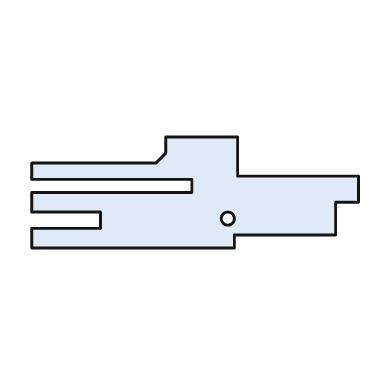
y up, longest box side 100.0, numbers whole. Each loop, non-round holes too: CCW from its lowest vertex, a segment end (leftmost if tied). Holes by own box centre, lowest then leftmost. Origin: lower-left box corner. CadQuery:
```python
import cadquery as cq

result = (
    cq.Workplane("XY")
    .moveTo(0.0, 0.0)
    .lineTo(62.0, 0.0)
    .lineTo(62.0, 4.0)
    .lineTo(93.0, 4.0)
    .lineTo(93.0, 14.0)
    .lineTo(100.0, 14.0)
    .lineTo(100.0, 22.0)
    .lineTo(63.0, 22.0)
    .lineTo(63.0, 34.0)
    .lineTo(41.0, 34.0)
    .lineTo(41.0, 29.0)
    .lineTo(38.0, 26.0)
    .lineTo(0.0, 26.0)
    .lineTo(0.0, 21.0)
    .lineTo(49.0, 21.0)
    .lineTo(49.0, 17.0)
    .lineTo(0.0, 17.0)
    .lineTo(0.0, 11.0)
    .lineTo(21.0, 11.0)
    .lineTo(21.0, 6.0)
    .lineTo(0.0, 6.0)
    .close()
    .moveTo(60.0, 9.0)
    .circle(2.0)
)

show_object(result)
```